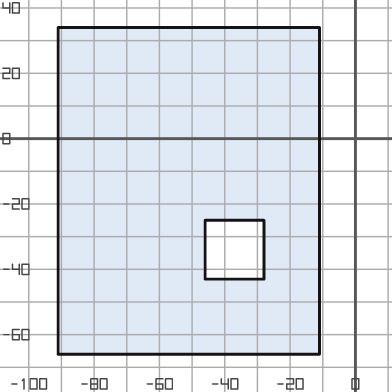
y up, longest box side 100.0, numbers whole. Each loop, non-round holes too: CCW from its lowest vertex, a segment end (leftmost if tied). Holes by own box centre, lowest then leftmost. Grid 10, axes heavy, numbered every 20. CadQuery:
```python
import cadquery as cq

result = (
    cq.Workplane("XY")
    .moveTo(-91.0, -66.0)
    .lineTo(-11.0, -66.0)
    .lineTo(-11.0, 34.0)
    .lineTo(-91.0, 34.0)
    .close()
    .moveTo(-46.0, -43.0)
    .lineTo(-28.0, -43.0)
    .lineTo(-28.0, -25.0)
    .lineTo(-46.0, -25.0)
    .close()
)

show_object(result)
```